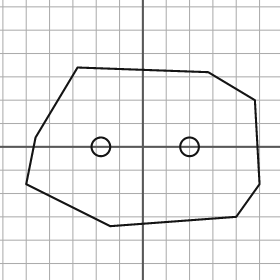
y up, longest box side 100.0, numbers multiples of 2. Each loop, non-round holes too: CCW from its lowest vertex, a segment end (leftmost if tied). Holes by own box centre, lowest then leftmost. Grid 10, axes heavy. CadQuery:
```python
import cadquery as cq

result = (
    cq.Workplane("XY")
    .moveTo(-14.0, -34.0)
    .lineTo(40.0, -30.0)
    .lineTo(50.0, -16.0)
    .lineTo(48.0, 20.0)
    .lineTo(28.0, 32.0)
    .lineTo(-28.0, 34.0)
    .lineTo(-46.0, 4.0)
    .lineTo(-50.0, -16.0)
    .close()
    .moveTo(-18.0, 0.0)
    .circle(4.0)
    .moveTo(20.0, 0.0)
    .circle(4.0)
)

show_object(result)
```